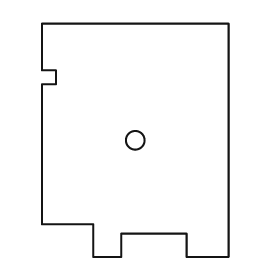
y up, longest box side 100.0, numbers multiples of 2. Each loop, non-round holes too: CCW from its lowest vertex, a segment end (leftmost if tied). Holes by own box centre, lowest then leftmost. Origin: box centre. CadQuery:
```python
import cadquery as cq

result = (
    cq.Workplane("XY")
    .moveTo(-18.0, -50.0)
    .lineTo(-6.0, -50.0)
    .lineTo(-6.0, -40.0)
    .lineTo(22.0, -40.0)
    .lineTo(22.0, -50.0)
    .lineTo(40.0, -50.0)
    .lineTo(40.0, 50.0)
    .lineTo(-40.0, 50.0)
    .lineTo(-40.0, 30.0)
    .lineTo(-34.0, 30.0)
    .lineTo(-34.0, 24.0)
    .lineTo(-40.0, 24.0)
    .lineTo(-40.0, -36.0)
    .lineTo(-18.0, -36.0)
    .close()
    .moveTo(0.0, 0.0)
    .circle(4.0)
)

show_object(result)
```